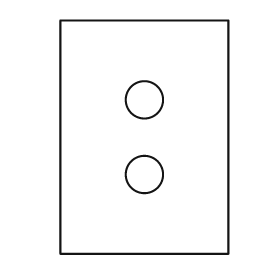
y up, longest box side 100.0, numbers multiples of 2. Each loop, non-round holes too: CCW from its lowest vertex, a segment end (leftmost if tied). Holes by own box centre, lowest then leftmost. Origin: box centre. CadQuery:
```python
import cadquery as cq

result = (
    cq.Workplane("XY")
    .moveTo(-36.0, -50.0)
    .lineTo(36.0, -50.0)
    .lineTo(36.0, 50.0)
    .lineTo(-36.0, 50.0)
    .close()
    .moveTo(0.0, -16.0)
    .circle(8.0)
    .moveTo(0.0, 16.0)
    .circle(8.0)
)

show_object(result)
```